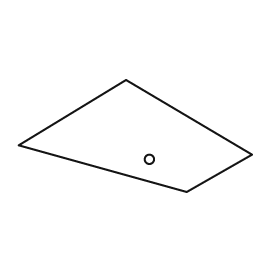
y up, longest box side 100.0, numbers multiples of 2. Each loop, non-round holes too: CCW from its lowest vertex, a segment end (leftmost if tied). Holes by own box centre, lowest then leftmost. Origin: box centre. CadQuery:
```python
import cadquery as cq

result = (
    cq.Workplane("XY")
    .moveTo(22.0, -24.0)
    .lineTo(50.0, -8.0)
    .lineTo(-4.0, 24.0)
    .lineTo(-50.0, -4.0)
    .close()
    .moveTo(6.0, -10.0)
    .circle(2.0)
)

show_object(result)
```